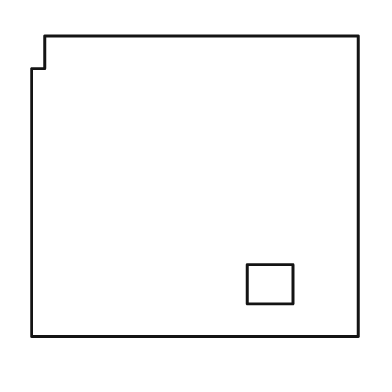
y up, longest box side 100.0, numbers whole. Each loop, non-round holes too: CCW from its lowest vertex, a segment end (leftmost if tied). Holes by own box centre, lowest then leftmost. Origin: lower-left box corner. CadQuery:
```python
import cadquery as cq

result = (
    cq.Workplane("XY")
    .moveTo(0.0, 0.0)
    .lineTo(100.0, 0.0)
    .lineTo(100.0, 92.0)
    .lineTo(4.0, 92.0)
    .lineTo(4.0, 82.0)
    .lineTo(0.0, 82.0)
    .close()
    .moveTo(66.0, 10.0)
    .lineTo(80.0, 10.0)
    .lineTo(80.0, 22.0)
    .lineTo(66.0, 22.0)
    .close()
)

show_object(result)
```